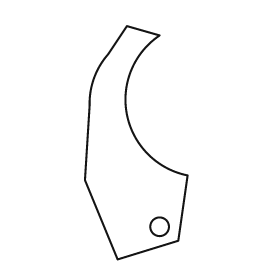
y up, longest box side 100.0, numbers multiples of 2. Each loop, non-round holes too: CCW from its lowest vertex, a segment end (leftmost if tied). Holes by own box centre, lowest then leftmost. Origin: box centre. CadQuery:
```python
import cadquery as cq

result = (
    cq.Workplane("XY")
    .moveTo(-8.0, -50.0)
    .lineTo(18.0, -42.0)
    .lineTo(22.0, -14.0)
    .threePointArc((-4.0, 12.0), (10.0, 46.0))
    .lineTo(-4.0, 50.0)
    .lineTo(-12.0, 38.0)
    .threePointArc((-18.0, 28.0), (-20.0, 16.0))
    .lineTo(-22.0, -16.0)
    .close()
    .moveTo(10.0, -36.0)
    .circle(4.0)
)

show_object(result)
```